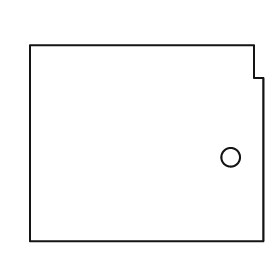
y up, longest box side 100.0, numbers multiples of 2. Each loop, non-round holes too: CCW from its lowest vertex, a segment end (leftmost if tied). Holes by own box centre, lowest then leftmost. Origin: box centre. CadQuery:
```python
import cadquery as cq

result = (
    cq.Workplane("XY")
    .moveTo(-50.0, -42.0)
    .lineTo(50.0, -42.0)
    .lineTo(50.0, 28.0)
    .lineTo(46.0, 28.0)
    .lineTo(46.0, 42.0)
    .lineTo(-50.0, 42.0)
    .close()
    .moveTo(36.0, -6.0)
    .circle(4.0)
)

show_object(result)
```